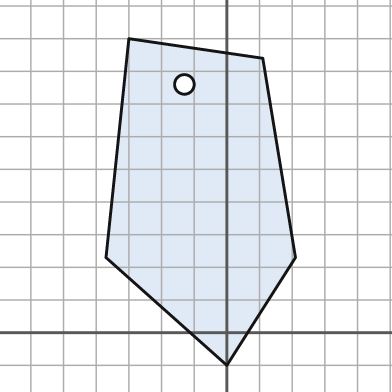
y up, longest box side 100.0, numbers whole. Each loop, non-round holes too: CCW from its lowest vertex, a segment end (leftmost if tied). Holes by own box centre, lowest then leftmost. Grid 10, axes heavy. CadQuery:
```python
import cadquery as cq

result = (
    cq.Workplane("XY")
    .moveTo(0.0, -10.0)
    .lineTo(21.0, 23.0)
    .lineTo(11.0, 84.0)
    .lineTo(-30.0, 90.0)
    .lineTo(-37.0, 23.0)
    .close()
    .moveTo(-13.0, 76.0)
    .circle(3.0)
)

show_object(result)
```